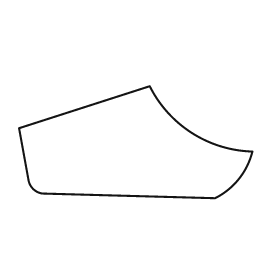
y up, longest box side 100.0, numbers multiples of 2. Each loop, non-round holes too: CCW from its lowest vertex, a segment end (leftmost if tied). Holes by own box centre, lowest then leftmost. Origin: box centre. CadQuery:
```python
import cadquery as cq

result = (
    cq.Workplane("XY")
    .moveTo(34.0, -24.0)
    .threePointArc((44.0, -16.0), (50.0, -4.0))
    .threePointArc((24.0, 4.0), (6.0, 24.0))
    .lineTo(-50.0, 6.0)
    .lineTo(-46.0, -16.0)
    .threePointArc((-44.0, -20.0), (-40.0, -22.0))
    .close()
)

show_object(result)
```